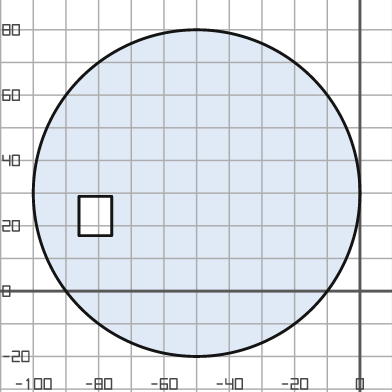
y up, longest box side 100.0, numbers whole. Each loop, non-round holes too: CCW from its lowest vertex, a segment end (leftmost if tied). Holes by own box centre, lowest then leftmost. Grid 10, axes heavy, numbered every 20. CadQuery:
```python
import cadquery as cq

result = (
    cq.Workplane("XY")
    .moveTo(-50.0, 30.0)
    .circle(50.0)
    .moveTo(-86.0, 17.0)
    .lineTo(-76.0, 17.0)
    .lineTo(-76.0, 29.0)
    .lineTo(-86.0, 29.0)
    .close()
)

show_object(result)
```